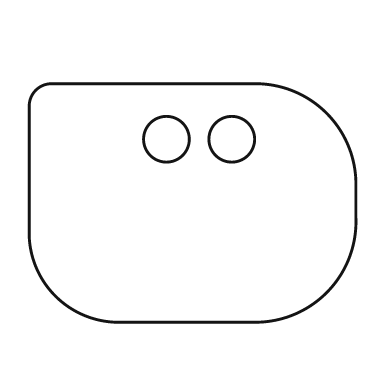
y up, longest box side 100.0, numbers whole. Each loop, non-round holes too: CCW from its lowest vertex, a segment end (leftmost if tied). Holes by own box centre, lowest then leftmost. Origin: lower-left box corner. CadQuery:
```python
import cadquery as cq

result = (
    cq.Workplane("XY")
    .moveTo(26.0, 0.0)
    .lineTo(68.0, 0.0)
    .threePointArc((91.0, 9.0), (100.0, 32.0))
    .lineTo(100.0, 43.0)
    .threePointArc((91.0, 64.0), (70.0, 73.0))
    .lineTo(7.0, 73.0)
    .threePointArc((2.0, 71.0), (0.0, 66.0))
    .lineTo(0.0, 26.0)
    .threePointArc((8.0, 8.0), (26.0, 0.0))
    .close()
    .moveTo(42.0, 56.0)
    .circle(7.0)
    .moveTo(62.0, 56.0)
    .circle(7.0)
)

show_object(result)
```